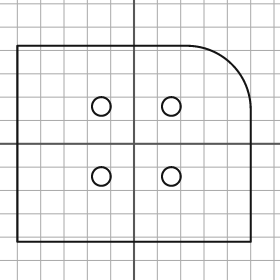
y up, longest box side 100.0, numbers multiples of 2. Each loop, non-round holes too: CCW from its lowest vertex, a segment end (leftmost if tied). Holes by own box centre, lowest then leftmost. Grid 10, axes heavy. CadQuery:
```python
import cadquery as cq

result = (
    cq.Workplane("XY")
    .moveTo(-50.0, -42.0)
    .lineTo(50.0, -42.0)
    .lineTo(50.0, 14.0)
    .threePointArc((42.0, 34.0), (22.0, 42.0))
    .lineTo(-50.0, 42.0)
    .close()
    .moveTo(-14.0, -14.0)
    .circle(4.0)
    .moveTo(16.0, -14.0)
    .circle(4.0)
    .moveTo(-14.0, 16.0)
    .circle(4.0)
    .moveTo(16.0, 16.0)
    .circle(4.0)
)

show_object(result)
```